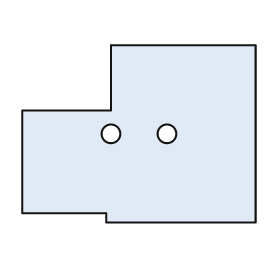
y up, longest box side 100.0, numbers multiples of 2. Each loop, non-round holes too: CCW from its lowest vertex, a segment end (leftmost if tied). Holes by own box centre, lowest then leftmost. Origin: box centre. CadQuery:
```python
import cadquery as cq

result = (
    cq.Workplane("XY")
    .moveTo(-14.0, -38.0)
    .lineTo(50.0, -38.0)
    .lineTo(50.0, 38.0)
    .lineTo(-12.0, 38.0)
    .lineTo(-12.0, 10.0)
    .lineTo(-50.0, 10.0)
    .lineTo(-50.0, -34.0)
    .lineTo(-14.0, -34.0)
    .close()
    .moveTo(-12.0, 0.0)
    .circle(4.0)
    .moveTo(12.0, 0.0)
    .circle(4.0)
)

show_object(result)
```